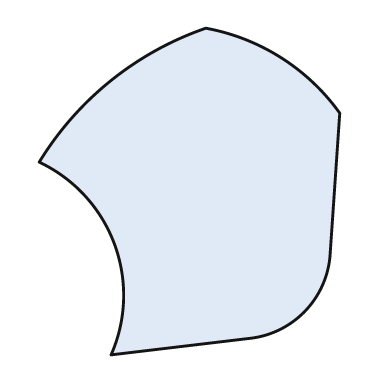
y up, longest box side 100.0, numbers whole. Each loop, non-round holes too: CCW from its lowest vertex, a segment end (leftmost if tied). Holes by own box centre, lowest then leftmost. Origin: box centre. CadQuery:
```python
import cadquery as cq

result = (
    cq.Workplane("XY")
    .moveTo(-24.0, -50.0)
    .lineTo(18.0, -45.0)
    .threePointArc((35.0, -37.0), (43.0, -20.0))
    .lineTo(46.0, 24.0)
    .threePointArc((28.0, 41.0), (5.0, 50.0))
    .threePointArc((-24.0, 34.0), (-46.0, 9.0))
    .threePointArc((-23.0, -16.0), (-24.0, -50.0))
    .close()
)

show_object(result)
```